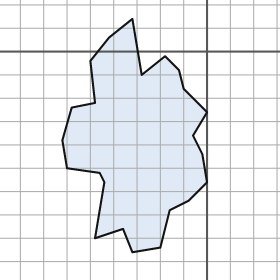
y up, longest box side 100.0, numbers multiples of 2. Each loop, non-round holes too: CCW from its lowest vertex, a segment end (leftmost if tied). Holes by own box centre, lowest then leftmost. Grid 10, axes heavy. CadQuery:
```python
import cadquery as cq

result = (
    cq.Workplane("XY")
    .moveTo(-32.0, -86.0)
    .lineTo(-20.0, -84.0)
    .lineTo(-16.0, -68.0)
    .lineTo(-8.0, -64.0)
    .lineTo(0.0, -56.0)
    .lineTo(-2.0, -44.0)
    .lineTo(-6.0, -36.0)
    .lineTo(0.0, -26.0)
    .lineTo(-10.0, -16.0)
    .lineTo(-12.0, -8.0)
    .lineTo(-18.0, -2.0)
    .lineTo(-28.0, -10.0)
    .lineTo(-32.0, 14.0)
    .lineTo(-42.0, 6.0)
    .lineTo(-50.0, -4.0)
    .lineTo(-48.0, -22.0)
    .lineTo(-58.0, -24.0)
    .lineTo(-62.0, -38.0)
    .lineTo(-60.0, -50.0)
    .lineTo(-46.0, -52.0)
    .lineTo(-44.0, -56.0)
    .lineTo(-48.0, -80.0)
    .lineTo(-36.0, -76.0)
    .close()
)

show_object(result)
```